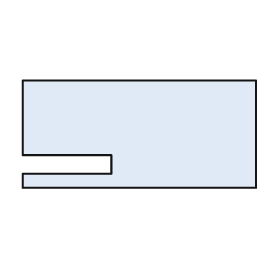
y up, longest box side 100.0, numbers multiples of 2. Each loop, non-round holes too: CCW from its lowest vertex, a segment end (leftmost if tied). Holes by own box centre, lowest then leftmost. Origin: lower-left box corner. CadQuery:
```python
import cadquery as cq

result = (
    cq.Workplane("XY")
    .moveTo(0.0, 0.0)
    .lineTo(100.0, 0.0)
    .lineTo(100.0, 46.0)
    .lineTo(0.0, 46.0)
    .lineTo(0.0, 14.0)
    .lineTo(38.0, 14.0)
    .lineTo(38.0, 6.0)
    .lineTo(0.0, 6.0)
    .close()
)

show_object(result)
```